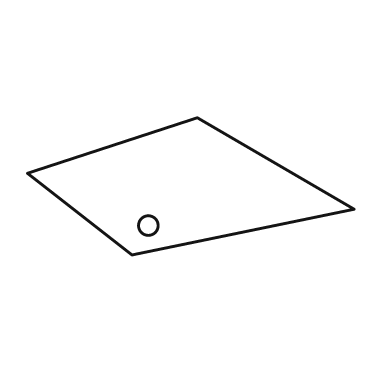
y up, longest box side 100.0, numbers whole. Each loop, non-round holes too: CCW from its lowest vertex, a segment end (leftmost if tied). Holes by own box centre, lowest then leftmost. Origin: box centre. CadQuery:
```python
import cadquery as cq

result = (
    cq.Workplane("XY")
    .moveTo(-18.0, -21.0)
    .lineTo(50.0, -7.0)
    .lineTo(2.0, 21.0)
    .lineTo(-50.0, 4.0)
    .close()
    .moveTo(-13.0, -12.0)
    .circle(3.0)
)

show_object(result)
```